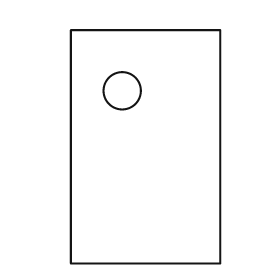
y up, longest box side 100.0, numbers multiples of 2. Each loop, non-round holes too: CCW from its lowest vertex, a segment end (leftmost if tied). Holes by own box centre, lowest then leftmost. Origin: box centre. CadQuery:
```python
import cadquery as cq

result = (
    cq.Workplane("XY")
    .moveTo(-32.0, -50.0)
    .lineTo(32.0, -50.0)
    .lineTo(32.0, 50.0)
    .lineTo(-32.0, 50.0)
    .close()
    .moveTo(-10.0, 24.0)
    .circle(8.0)
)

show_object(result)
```